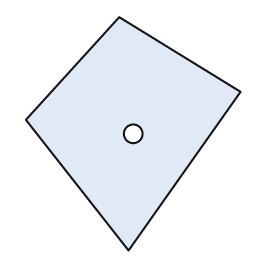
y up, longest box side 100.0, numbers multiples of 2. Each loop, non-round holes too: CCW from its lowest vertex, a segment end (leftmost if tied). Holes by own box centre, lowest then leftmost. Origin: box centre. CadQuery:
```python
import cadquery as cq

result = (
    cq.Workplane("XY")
    .moveTo(-2.0, -50.0)
    .lineTo(46.0, 18.0)
    .lineTo(-6.0, 50.0)
    .lineTo(-46.0, 6.0)
    .close()
    .moveTo(0.0, 0.0)
    .circle(4.0)
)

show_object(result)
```